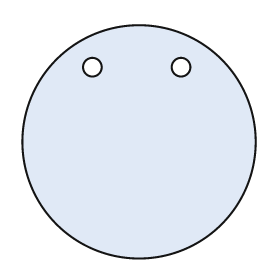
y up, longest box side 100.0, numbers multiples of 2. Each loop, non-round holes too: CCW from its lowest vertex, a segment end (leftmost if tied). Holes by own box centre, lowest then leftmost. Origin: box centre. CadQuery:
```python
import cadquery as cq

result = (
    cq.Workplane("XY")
    .moveTo(0.0, 0.0)
    .circle(50.0)
    .moveTo(-20.0, 32.0)
    .circle(4.0)
    .moveTo(18.0, 32.0)
    .circle(4.0)
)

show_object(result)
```